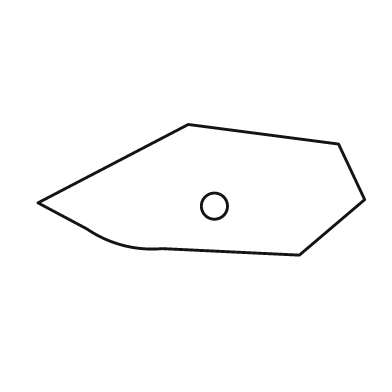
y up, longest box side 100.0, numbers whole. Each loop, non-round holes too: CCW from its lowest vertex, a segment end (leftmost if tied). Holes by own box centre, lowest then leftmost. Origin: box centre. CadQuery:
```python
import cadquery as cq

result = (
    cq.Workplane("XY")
    .moveTo(30.0, -20.0)
    .lineTo(50.0, -3.0)
    .lineTo(42.0, 14.0)
    .lineTo(-4.0, 20.0)
    .lineTo(-50.0, -4.0)
    .lineTo(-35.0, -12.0)
    .threePointArc((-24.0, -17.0), (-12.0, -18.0))
    .close()
    .moveTo(4.0, -5.0)
    .circle(4.0)
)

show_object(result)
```